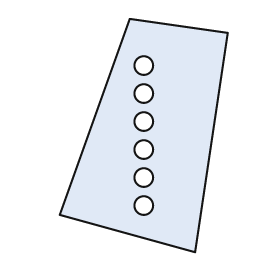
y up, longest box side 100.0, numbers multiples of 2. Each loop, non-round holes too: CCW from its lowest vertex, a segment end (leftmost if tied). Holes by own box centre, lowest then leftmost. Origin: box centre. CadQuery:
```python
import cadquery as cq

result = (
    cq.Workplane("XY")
    .moveTo(22.0, -50.0)
    .lineTo(36.0, 44.0)
    .lineTo(-6.0, 50.0)
    .lineTo(-36.0, -34.0)
    .close()
    .moveTo(0.0, -30.0)
    .circle(4.0)
    .moveTo(0.0, -18.0)
    .circle(4.0)
    .moveTo(0.0, -6.0)
    .circle(4.0)
    .moveTo(0.0, 6.0)
    .circle(4.0)
    .moveTo(0.0, 18.0)
    .circle(4.0)
    .moveTo(0.0, 30.0)
    .circle(4.0)
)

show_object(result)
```